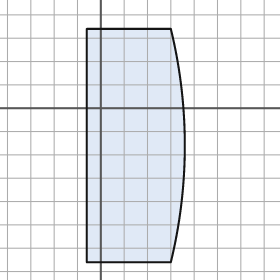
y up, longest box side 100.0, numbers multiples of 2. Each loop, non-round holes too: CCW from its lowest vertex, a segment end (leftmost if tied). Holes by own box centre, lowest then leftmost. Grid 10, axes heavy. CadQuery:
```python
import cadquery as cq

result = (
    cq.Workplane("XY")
    .moveTo(-6.0, -66.0)
    .lineTo(30.0, -66.0)
    .threePointArc((36.0, -16.0), (30.0, 34.0))
    .lineTo(-6.0, 34.0)
    .close()
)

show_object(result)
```